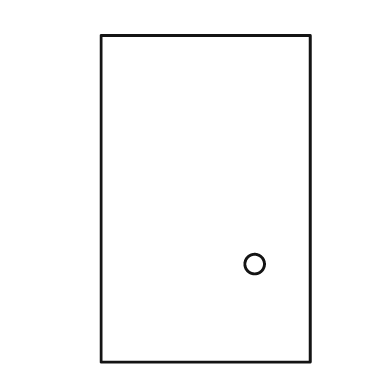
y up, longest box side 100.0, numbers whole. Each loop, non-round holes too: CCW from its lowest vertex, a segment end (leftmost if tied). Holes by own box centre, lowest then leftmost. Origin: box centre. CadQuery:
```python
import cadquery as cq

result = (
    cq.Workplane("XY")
    .moveTo(-32.0, -50.0)
    .lineTo(32.0, -50.0)
    .lineTo(32.0, 50.0)
    .lineTo(-32.0, 50.0)
    .close()
    .moveTo(15.0, -20.0)
    .circle(3.0)
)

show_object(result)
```